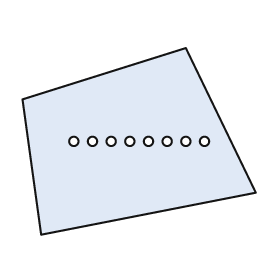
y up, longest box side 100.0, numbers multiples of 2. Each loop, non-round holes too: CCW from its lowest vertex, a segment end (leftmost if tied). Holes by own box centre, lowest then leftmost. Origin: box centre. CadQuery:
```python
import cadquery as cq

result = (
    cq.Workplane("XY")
    .moveTo(-42.0, -40.0)
    .lineTo(50.0, -22.0)
    .lineTo(20.0, 40.0)
    .lineTo(-50.0, 18.0)
    .close()
    .moveTo(-28.0, 0.0)
    .circle(2.0)
    .moveTo(-20.0, 0.0)
    .circle(2.0)
    .moveTo(-12.0, 0.0)
    .circle(2.0)
    .moveTo(-4.0, 0.0)
    .circle(2.0)
    .moveTo(4.0, 0.0)
    .circle(2.0)
    .moveTo(12.0, 0.0)
    .circle(2.0)
    .moveTo(20.0, 0.0)
    .circle(2.0)
    .moveTo(28.0, 0.0)
    .circle(2.0)
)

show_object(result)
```